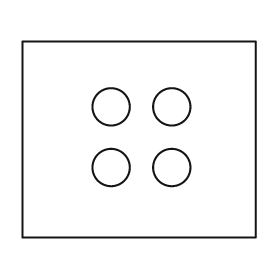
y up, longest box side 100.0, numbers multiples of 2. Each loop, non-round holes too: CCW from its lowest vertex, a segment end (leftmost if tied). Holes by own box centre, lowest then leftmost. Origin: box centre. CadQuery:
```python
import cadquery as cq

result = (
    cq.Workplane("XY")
    .moveTo(-50.0, -42.0)
    .lineTo(50.0, -42.0)
    .lineTo(50.0, 42.0)
    .lineTo(-50.0, 42.0)
    .close()
    .moveTo(-12.0, -12.0)
    .circle(8.0)
    .moveTo(14.0, -12.0)
    .circle(8.0)
    .moveTo(-12.0, 14.0)
    .circle(8.0)
    .moveTo(14.0, 14.0)
    .circle(8.0)
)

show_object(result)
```